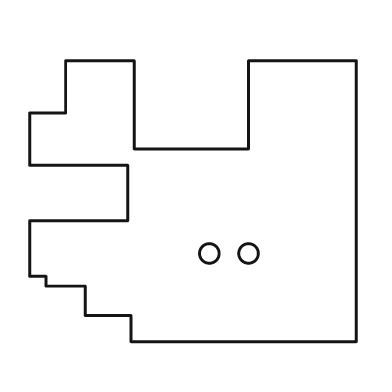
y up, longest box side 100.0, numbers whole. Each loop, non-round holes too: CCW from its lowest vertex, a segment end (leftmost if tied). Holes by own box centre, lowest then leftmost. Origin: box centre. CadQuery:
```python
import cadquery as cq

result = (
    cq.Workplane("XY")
    .moveTo(-19.0, -43.0)
    .lineTo(50.0, -43.0)
    .lineTo(50.0, 43.0)
    .lineTo(17.0, 43.0)
    .lineTo(17.0, 16.0)
    .lineTo(-18.0, 16.0)
    .lineTo(-18.0, 43.0)
    .lineTo(-39.0, 43.0)
    .lineTo(-39.0, 27.0)
    .lineTo(-50.0, 27.0)
    .lineTo(-50.0, 11.0)
    .lineTo(-20.0, 11.0)
    .lineTo(-20.0, -6.0)
    .lineTo(-50.0, -6.0)
    .lineTo(-50.0, -23.0)
    .lineTo(-45.0, -23.0)
    .lineTo(-45.0, -26.0)
    .lineTo(-33.0, -26.0)
    .lineTo(-33.0, -35.0)
    .lineTo(-19.0, -35.0)
    .close()
    .moveTo(5.0, -16.0)
    .circle(3.0)
    .moveTo(17.0, -16.0)
    .circle(3.0)
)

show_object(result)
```